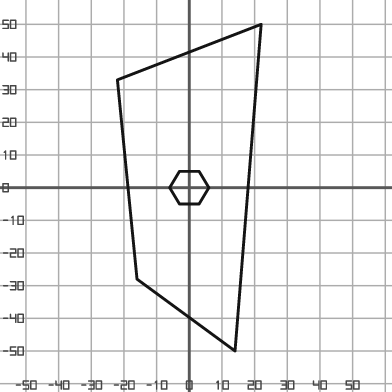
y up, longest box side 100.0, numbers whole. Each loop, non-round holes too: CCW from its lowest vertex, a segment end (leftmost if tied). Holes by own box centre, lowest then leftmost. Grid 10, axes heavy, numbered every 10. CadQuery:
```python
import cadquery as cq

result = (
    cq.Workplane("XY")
    .moveTo(14.0, -50.0)
    .lineTo(22.0, 50.0)
    .lineTo(-22.0, 33.0)
    .lineTo(-16.0, -28.0)
    .close()
    .moveTo(-3.0, -5.0)
    .lineTo(3.0, -5.0)
    .lineTo(6.0, 0.0)
    .lineTo(3.0, 5.0)
    .lineTo(-3.0, 5.0)
    .lineTo(-6.0, 0.0)
    .close()
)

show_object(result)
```